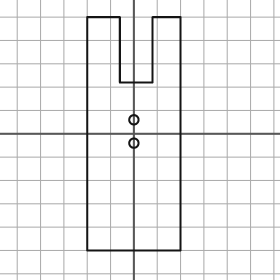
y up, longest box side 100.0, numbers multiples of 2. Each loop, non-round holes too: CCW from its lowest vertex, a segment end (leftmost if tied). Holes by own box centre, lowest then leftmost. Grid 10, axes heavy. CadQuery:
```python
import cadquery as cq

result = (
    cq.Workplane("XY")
    .moveTo(-20.0, -50.0)
    .lineTo(20.0, -50.0)
    .lineTo(20.0, 50.0)
    .lineTo(8.0, 50.0)
    .lineTo(8.0, 22.0)
    .lineTo(-6.0, 22.0)
    .lineTo(-6.0, 50.0)
    .lineTo(-20.0, 50.0)
    .close()
    .moveTo(0.0, -4.0)
    .circle(2.0)
    .moveTo(0.0, 6.0)
    .circle(2.0)
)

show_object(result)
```